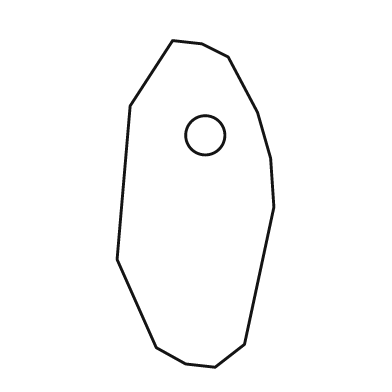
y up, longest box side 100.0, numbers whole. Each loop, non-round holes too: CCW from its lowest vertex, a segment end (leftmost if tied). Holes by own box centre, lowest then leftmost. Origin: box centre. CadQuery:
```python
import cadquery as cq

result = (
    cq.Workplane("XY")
    .moveTo(6.0, -50.0)
    .lineTo(15.0, -43.0)
    .lineTo(24.0, -1.0)
    .lineTo(23.0, 14.0)
    .lineTo(19.0, 28.0)
    .lineTo(10.0, 45.0)
    .lineTo(2.0, 49.0)
    .lineTo(-7.0, 50.0)
    .lineTo(-20.0, 30.0)
    .lineTo(-24.0, -17.0)
    .lineTo(-12.0, -44.0)
    .lineTo(-3.0, -49.0)
    .close()
    .moveTo(3.0, 21.0)
    .circle(6.0)
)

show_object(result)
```